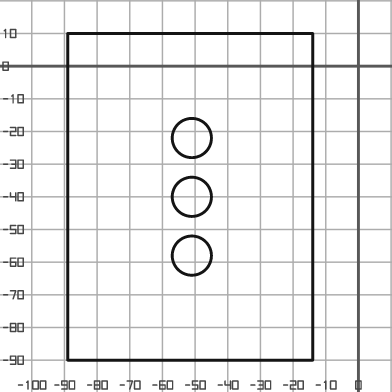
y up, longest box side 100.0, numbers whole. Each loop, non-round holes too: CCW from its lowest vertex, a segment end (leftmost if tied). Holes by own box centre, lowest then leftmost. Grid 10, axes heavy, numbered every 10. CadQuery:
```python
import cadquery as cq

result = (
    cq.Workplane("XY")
    .moveTo(-89.0, -90.0)
    .lineTo(-14.0, -90.0)
    .lineTo(-14.0, 10.0)
    .lineTo(-89.0, 10.0)
    .close()
    .moveTo(-51.0, -58.0)
    .circle(6.0)
    .moveTo(-51.0, -40.0)
    .circle(6.0)
    .moveTo(-51.0, -22.0)
    .circle(6.0)
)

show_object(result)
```